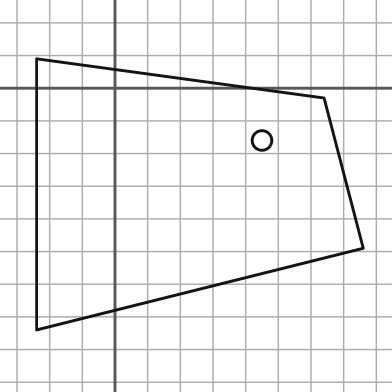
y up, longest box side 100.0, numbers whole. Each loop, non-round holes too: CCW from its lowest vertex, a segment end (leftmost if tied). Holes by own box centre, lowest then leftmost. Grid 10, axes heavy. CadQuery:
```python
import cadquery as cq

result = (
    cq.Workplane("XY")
    .moveTo(-24.0, -74.0)
    .lineTo(76.0, -49.0)
    .lineTo(64.0, -3.0)
    .lineTo(-24.0, 9.0)
    .close()
    .moveTo(45.0, -16.0)
    .circle(3.0)
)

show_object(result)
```